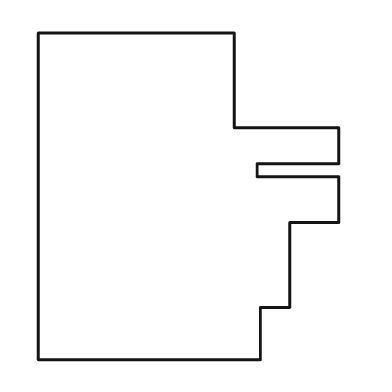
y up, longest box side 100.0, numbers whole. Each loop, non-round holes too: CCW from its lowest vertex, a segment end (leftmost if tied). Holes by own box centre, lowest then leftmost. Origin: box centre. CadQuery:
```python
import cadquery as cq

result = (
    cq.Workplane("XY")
    .moveTo(-46.0, -50.0)
    .lineTo(22.0, -50.0)
    .lineTo(22.0, -34.0)
    .lineTo(31.0, -34.0)
    .lineTo(31.0, -8.0)
    .lineTo(46.0, -8.0)
    .lineTo(46.0, 6.0)
    .lineTo(21.0, 6.0)
    .lineTo(21.0, 10.0)
    .lineTo(46.0, 10.0)
    .lineTo(46.0, 21.0)
    .lineTo(14.0, 21.0)
    .lineTo(14.0, 50.0)
    .lineTo(-46.0, 50.0)
    .close()
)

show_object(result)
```